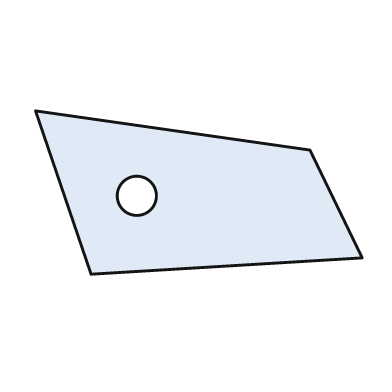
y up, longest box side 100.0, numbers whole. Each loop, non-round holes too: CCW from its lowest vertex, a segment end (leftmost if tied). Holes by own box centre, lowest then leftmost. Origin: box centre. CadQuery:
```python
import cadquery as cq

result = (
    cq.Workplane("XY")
    .moveTo(-33.0, -25.0)
    .lineTo(50.0, -20.0)
    .lineTo(34.0, 13.0)
    .lineTo(-50.0, 25.0)
    .close()
    .moveTo(-19.0, -1.0)
    .circle(6.0)
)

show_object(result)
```